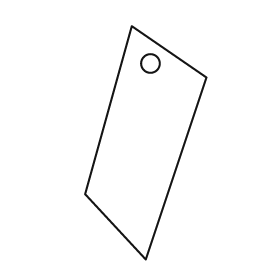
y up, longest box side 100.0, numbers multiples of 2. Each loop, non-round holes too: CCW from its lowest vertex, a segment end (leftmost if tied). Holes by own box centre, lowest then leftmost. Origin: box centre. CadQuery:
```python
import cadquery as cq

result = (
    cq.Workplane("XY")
    .moveTo(0.0, -50.0)
    .lineTo(26.0, 28.0)
    .lineTo(-6.0, 50.0)
    .lineTo(-26.0, -22.0)
    .close()
    .moveTo(2.0, 34.0)
    .circle(4.0)
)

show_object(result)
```